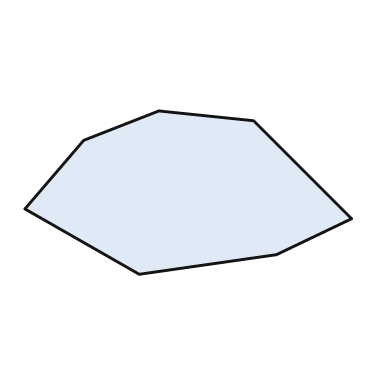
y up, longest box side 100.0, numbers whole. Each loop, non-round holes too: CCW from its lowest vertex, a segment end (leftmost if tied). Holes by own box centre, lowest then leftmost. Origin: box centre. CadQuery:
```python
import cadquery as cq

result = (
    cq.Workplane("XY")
    .moveTo(-15.0, -25.0)
    .lineTo(27.0, -19.0)
    .lineTo(50.0, -8.0)
    .lineTo(20.0, 22.0)
    .lineTo(-9.0, 25.0)
    .lineTo(-32.0, 16.0)
    .lineTo(-50.0, -5.0)
    .close()
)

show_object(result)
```